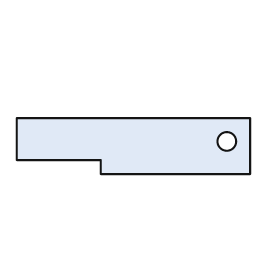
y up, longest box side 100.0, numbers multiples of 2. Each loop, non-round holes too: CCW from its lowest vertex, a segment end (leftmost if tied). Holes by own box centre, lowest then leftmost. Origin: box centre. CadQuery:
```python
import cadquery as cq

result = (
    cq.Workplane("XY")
    .moveTo(-14.0, -12.0)
    .lineTo(50.0, -12.0)
    .lineTo(50.0, 12.0)
    .lineTo(-50.0, 12.0)
    .lineTo(-50.0, -6.0)
    .lineTo(-14.0, -6.0)
    .close()
    .moveTo(40.0, 2.0)
    .circle(4.0)
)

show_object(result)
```